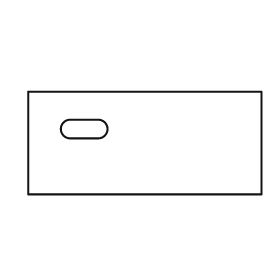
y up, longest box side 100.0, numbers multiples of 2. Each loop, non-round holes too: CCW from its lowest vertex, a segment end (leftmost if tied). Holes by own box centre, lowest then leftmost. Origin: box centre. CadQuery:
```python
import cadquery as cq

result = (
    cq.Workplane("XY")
    .moveTo(-50.0, -22.0)
    .lineTo(50.0, -22.0)
    .lineTo(50.0, 22.0)
    .lineTo(-50.0, 22.0)
    .close()
    .moveTo(-32.0, 2.0)
    .lineTo(-20.0, 2.0)
    .threePointArc((-16.0, 6.0), (-20.0, 10.0))
    .lineTo(-32.0, 10.0)
    .threePointArc((-36.0, 6.0), (-32.0, 2.0))
    .close()
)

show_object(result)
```